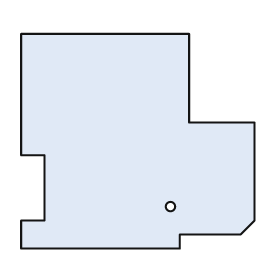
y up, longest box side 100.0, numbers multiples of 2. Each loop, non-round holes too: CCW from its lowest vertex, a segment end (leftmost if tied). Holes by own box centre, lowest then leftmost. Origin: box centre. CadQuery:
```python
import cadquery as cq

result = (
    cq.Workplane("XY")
    .moveTo(-50.0, -46.0)
    .lineTo(18.0, -46.0)
    .lineTo(18.0, -40.0)
    .lineTo(44.0, -40.0)
    .lineTo(50.0, -34.0)
    .lineTo(50.0, 8.0)
    .lineTo(22.0, 8.0)
    .lineTo(22.0, 46.0)
    .lineTo(-50.0, 46.0)
    .lineTo(-50.0, -6.0)
    .lineTo(-40.0, -6.0)
    .lineTo(-40.0, -34.0)
    .lineTo(-50.0, -34.0)
    .close()
    .moveTo(14.0, -28.0)
    .circle(2.0)
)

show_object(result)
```